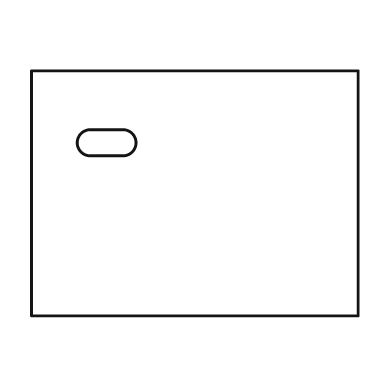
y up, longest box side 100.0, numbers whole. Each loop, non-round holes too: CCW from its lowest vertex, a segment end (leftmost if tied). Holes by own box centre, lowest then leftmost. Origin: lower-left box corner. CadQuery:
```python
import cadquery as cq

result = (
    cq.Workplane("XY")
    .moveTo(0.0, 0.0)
    .lineTo(100.0, 0.0)
    .lineTo(100.0, 75.0)
    .lineTo(0.0, 75.0)
    .close()
    .moveTo(18.0, 49.0)
    .lineTo(28.0, 49.0)
    .threePointArc((32.0, 53.0), (28.0, 57.0))
    .lineTo(18.0, 57.0)
    .threePointArc((14.0, 53.0), (18.0, 49.0))
    .close()
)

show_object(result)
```